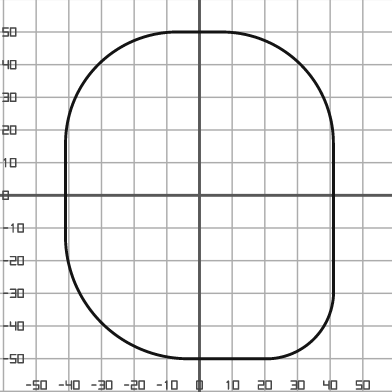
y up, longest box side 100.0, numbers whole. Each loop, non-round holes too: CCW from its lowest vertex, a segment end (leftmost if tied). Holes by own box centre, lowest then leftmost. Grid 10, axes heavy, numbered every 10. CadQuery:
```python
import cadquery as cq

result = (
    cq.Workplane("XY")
    .moveTo(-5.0, -50.0)
    .lineTo(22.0, -50.0)
    .threePointArc((35.0, -44.0), (41.0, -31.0))
    .lineTo(41.0, 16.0)
    .threePointArc((31.0, 40.0), (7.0, 50.0))
    .lineTo(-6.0, 50.0)
    .threePointArc((-31.0, 40.0), (-41.0, 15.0))
    .lineTo(-41.0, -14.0)
    .threePointArc((-30.0, -39.0), (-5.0, -50.0))
    .close()
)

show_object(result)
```